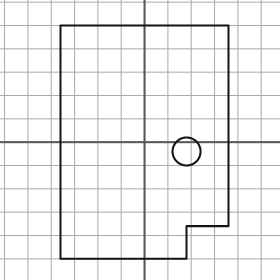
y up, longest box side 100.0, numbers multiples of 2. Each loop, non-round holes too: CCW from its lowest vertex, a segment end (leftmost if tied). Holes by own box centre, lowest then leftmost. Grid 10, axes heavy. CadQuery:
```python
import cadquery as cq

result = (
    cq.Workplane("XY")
    .moveTo(-36.0, -50.0)
    .lineTo(18.0, -50.0)
    .lineTo(18.0, -36.0)
    .lineTo(36.0, -36.0)
    .lineTo(36.0, 50.0)
    .lineTo(-36.0, 50.0)
    .close()
    .moveTo(18.0, -4.0)
    .circle(6.0)
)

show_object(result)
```